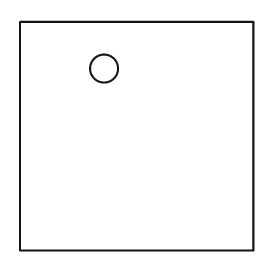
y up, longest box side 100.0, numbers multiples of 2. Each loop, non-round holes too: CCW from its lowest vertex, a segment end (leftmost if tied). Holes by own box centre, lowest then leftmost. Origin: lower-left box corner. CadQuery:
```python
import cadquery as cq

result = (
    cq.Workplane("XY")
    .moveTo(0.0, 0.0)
    .lineTo(100.0, 0.0)
    .lineTo(100.0, 98.0)
    .lineTo(0.0, 98.0)
    .close()
    .moveTo(36.0, 78.0)
    .circle(6.0)
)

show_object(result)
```